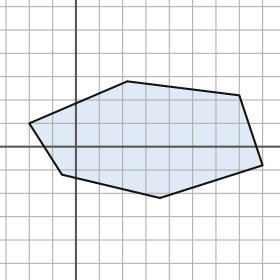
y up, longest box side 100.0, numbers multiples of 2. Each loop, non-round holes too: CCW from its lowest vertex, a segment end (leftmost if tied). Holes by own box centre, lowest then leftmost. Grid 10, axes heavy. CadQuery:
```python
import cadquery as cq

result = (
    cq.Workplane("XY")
    .moveTo(36.0, -22.0)
    .lineTo(80.0, -8.0)
    .lineTo(70.0, 22.0)
    .lineTo(22.0, 28.0)
    .lineTo(-20.0, 10.0)
    .lineTo(-6.0, -12.0)
    .close()
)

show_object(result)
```